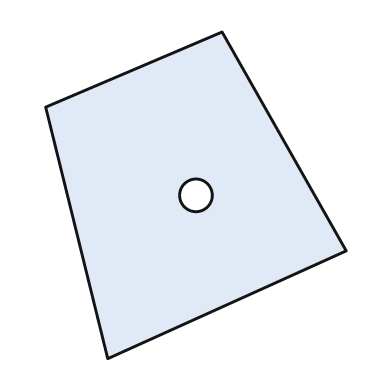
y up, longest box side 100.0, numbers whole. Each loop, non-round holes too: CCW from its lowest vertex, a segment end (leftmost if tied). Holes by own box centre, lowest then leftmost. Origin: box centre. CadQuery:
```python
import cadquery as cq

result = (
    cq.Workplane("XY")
    .moveTo(-27.0, -50.0)
    .lineTo(46.0, -17.0)
    .lineTo(8.0, 50.0)
    .lineTo(-46.0, 27.0)
    .close()
    .moveTo(0.0, 0.0)
    .circle(5.0)
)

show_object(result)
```